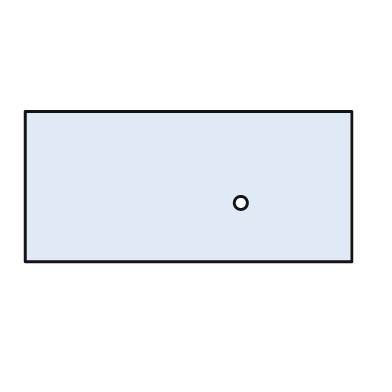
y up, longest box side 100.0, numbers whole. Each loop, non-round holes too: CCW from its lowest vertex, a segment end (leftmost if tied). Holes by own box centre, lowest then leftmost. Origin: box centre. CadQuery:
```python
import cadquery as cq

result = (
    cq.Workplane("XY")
    .moveTo(-50.0, -23.0)
    .lineTo(50.0, -23.0)
    .lineTo(50.0, 23.0)
    .lineTo(-50.0, 23.0)
    .close()
    .moveTo(16.0, -5.0)
    .circle(2.0)
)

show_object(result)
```